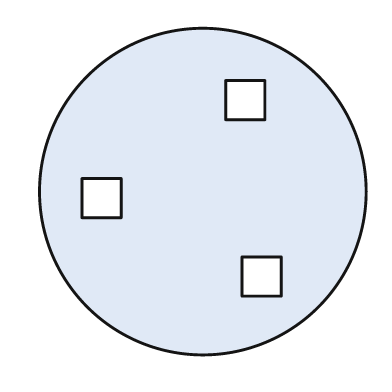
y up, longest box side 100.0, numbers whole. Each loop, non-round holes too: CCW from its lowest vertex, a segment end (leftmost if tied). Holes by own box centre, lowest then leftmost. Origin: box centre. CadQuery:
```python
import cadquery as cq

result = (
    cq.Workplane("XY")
    .moveTo(0.0, 0.0)
    .circle(50.0)
    .moveTo(12.0, -32.0)
    .lineTo(24.0, -32.0)
    .lineTo(24.0, -20.0)
    .lineTo(12.0, -20.0)
    .close()
    .moveTo(-37.0, -8.0)
    .lineTo(-25.0, -8.0)
    .lineTo(-25.0, 4.0)
    .lineTo(-37.0, 4.0)
    .close()
    .moveTo(7.0, 22.0)
    .lineTo(19.0, 22.0)
    .lineTo(19.0, 34.0)
    .lineTo(7.0, 34.0)
    .close()
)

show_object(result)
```